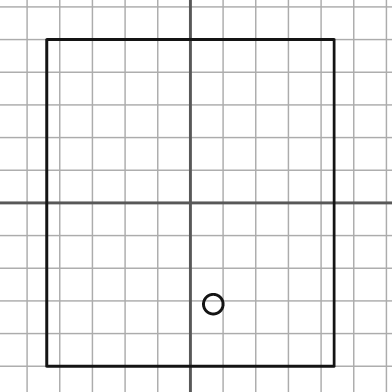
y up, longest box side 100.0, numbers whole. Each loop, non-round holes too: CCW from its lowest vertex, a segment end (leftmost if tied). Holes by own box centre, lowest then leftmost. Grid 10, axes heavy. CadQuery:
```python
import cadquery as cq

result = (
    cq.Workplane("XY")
    .moveTo(-44.0, -50.0)
    .lineTo(44.0, -50.0)
    .lineTo(44.0, 50.0)
    .lineTo(-44.0, 50.0)
    .close()
    .moveTo(7.0, -31.0)
    .circle(3.0)
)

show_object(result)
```